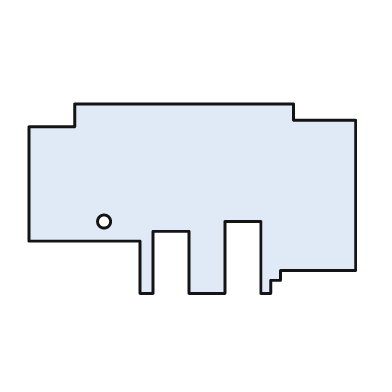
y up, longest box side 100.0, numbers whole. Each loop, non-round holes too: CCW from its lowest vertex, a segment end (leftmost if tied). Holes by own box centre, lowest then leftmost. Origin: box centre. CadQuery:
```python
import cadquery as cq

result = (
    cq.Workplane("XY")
    .moveTo(-16.0, -29.0)
    .lineTo(-12.0, -29.0)
    .lineTo(-12.0, -10.0)
    .lineTo(-1.0, -10.0)
    .lineTo(-1.0, -29.0)
    .lineTo(10.0, -29.0)
    .lineTo(10.0, -7.0)
    .lineTo(21.0, -7.0)
    .lineTo(21.0, -29.0)
    .lineTo(24.0, -29.0)
    .lineTo(24.0, -25.0)
    .lineTo(27.0, -25.0)
    .lineTo(27.0, -22.0)
    .lineTo(50.0, -22.0)
    .lineTo(50.0, 24.0)
    .lineTo(31.0, 24.0)
    .lineTo(31.0, 29.0)
    .lineTo(-36.0, 29.0)
    .lineTo(-36.0, 22.0)
    .lineTo(-50.0, 22.0)
    .lineTo(-50.0, -13.0)
    .lineTo(-16.0, -13.0)
    .close()
    .moveTo(-27.0, -7.0)
    .circle(2.0)
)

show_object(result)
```